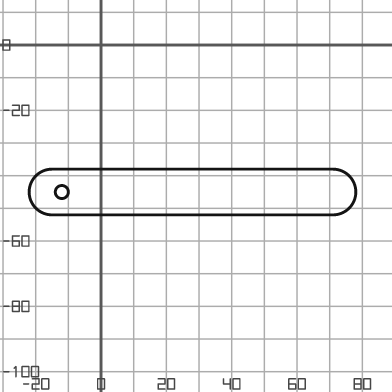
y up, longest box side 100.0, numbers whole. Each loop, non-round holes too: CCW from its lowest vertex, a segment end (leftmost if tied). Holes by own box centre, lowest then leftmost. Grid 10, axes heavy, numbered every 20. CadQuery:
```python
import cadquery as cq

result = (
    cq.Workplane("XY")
    .moveTo(-15.0, -52.0)
    .lineTo(71.0, -52.0)
    .threePointArc((78.0, -45.0), (71.0, -38.0))
    .lineTo(-15.0, -38.0)
    .threePointArc((-22.0, -45.0), (-15.0, -52.0))
    .close()
    .moveTo(-12.0, -45.0)
    .circle(2.0)
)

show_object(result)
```